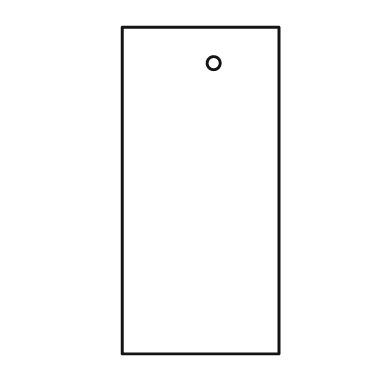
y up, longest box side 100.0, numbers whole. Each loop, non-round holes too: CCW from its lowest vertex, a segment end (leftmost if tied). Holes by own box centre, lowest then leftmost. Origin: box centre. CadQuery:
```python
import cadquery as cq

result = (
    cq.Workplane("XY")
    .moveTo(-24.0, -50.0)
    .lineTo(24.0, -50.0)
    .lineTo(24.0, 50.0)
    .lineTo(-24.0, 50.0)
    .close()
    .moveTo(4.0, 39.0)
    .circle(2.0)
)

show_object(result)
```